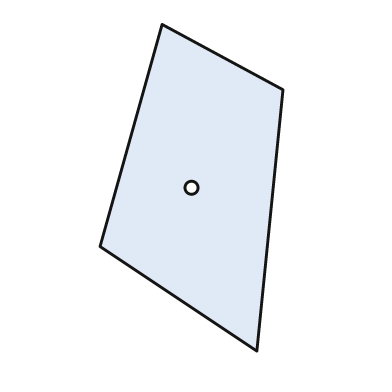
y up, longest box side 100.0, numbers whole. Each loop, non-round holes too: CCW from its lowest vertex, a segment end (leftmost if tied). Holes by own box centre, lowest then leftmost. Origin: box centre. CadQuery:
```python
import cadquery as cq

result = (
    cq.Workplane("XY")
    .moveTo(20.0, -50.0)
    .lineTo(28.0, 30.0)
    .lineTo(-9.0, 50.0)
    .lineTo(-28.0, -18.0)
    .close()
    .moveTo(0.0, 0.0)
    .circle(2.0)
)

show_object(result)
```